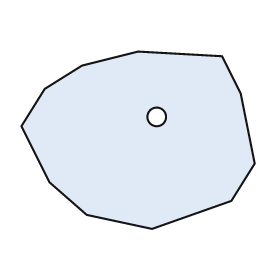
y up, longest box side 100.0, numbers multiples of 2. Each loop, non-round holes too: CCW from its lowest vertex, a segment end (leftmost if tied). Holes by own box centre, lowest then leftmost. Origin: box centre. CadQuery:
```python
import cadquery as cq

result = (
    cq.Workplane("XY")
    .moveTo(6.0, -38.0)
    .lineTo(40.0, -26.0)
    .lineTo(50.0, -10.0)
    .lineTo(44.0, 20.0)
    .lineTo(36.0, 36.0)
    .lineTo(0.0, 38.0)
    .lineTo(-24.0, 32.0)
    .lineTo(-40.0, 22.0)
    .lineTo(-50.0, 6.0)
    .lineTo(-38.0, -18.0)
    .lineTo(-22.0, -32.0)
    .close()
    .moveTo(8.0, 10.0)
    .circle(4.0)
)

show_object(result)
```